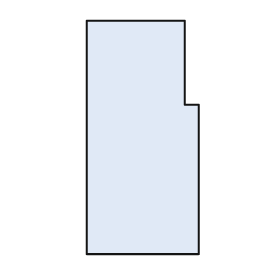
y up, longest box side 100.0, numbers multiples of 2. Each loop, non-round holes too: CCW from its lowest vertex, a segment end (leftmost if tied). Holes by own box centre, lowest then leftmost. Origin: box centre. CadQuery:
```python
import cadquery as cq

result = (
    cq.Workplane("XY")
    .moveTo(-24.0, -50.0)
    .lineTo(24.0, -50.0)
    .lineTo(24.0, 14.0)
    .lineTo(18.0, 14.0)
    .lineTo(18.0, 50.0)
    .lineTo(-24.0, 50.0)
    .close()
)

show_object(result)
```